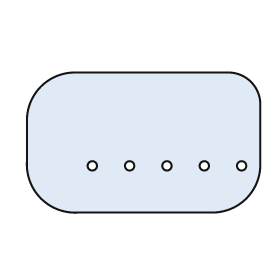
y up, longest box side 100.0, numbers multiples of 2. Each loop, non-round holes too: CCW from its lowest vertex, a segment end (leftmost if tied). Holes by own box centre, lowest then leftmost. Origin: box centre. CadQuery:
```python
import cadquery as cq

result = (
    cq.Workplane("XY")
    .moveTo(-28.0, -30.0)
    .lineTo(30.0, -30.0)
    .threePointArc((44.0, -24.0), (50.0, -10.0))
    .lineTo(50.0, 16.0)
    .threePointArc((46.0, 26.0), (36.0, 30.0))
    .lineTo(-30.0, 30.0)
    .threePointArc((-44.0, 24.0), (-50.0, 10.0))
    .lineTo(-50.0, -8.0)
    .threePointArc((-44.0, -24.0), (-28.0, -30.0))
    .close()
    .moveTo(-22.0, -10.0)
    .circle(2.0)
    .moveTo(-6.0, -10.0)
    .circle(2.0)
    .moveTo(10.0, -10.0)
    .circle(2.0)
    .moveTo(26.0, -10.0)
    .circle(2.0)
    .moveTo(42.0, -10.0)
    .circle(2.0)
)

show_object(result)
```